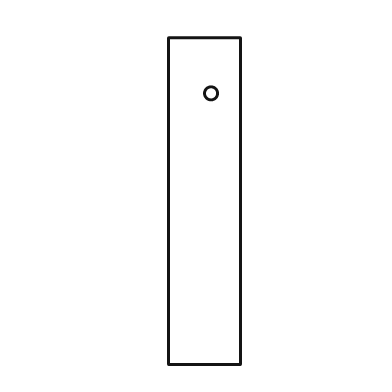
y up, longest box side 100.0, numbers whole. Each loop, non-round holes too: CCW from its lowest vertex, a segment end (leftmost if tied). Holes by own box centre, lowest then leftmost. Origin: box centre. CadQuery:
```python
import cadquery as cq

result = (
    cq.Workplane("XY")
    .moveTo(-11.0, -50.0)
    .lineTo(11.0, -50.0)
    .lineTo(11.0, 50.0)
    .lineTo(-11.0, 50.0)
    .close()
    .moveTo(2.0, 33.0)
    .circle(2.0)
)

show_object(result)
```